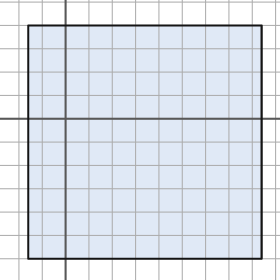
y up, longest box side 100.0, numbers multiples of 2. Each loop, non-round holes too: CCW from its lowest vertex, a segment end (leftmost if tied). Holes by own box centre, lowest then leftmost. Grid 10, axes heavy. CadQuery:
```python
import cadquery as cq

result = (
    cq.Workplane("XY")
    .moveTo(-16.0, -60.0)
    .lineTo(84.0, -60.0)
    .lineTo(84.0, 40.0)
    .lineTo(-16.0, 40.0)
    .close()
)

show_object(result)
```